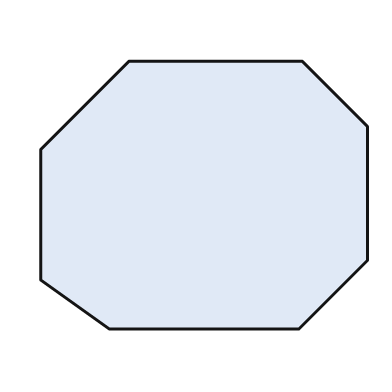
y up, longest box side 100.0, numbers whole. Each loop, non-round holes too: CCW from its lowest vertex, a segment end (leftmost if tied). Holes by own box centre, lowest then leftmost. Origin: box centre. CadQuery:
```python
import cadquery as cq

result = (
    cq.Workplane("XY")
    .moveTo(-29.0, -41.0)
    .lineTo(29.0, -41.0)
    .lineTo(50.0, -20.0)
    .lineTo(50.0, 21.0)
    .lineTo(30.0, 41.0)
    .lineTo(-23.0, 41.0)
    .lineTo(-50.0, 14.0)
    .lineTo(-50.0, -26.0)
    .close()
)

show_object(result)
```